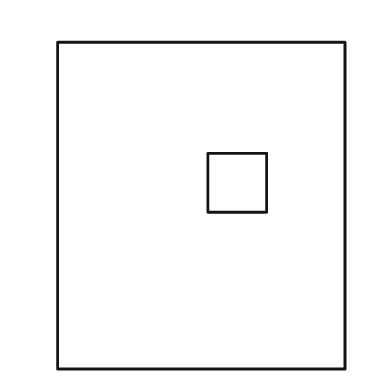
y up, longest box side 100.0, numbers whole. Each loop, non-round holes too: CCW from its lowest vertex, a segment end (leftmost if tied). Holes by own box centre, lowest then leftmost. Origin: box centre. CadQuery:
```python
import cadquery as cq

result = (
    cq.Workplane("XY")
    .moveTo(-44.0, -50.0)
    .lineTo(44.0, -50.0)
    .lineTo(44.0, 50.0)
    .lineTo(-44.0, 50.0)
    .close()
    .moveTo(2.0, -2.0)
    .lineTo(20.0, -2.0)
    .lineTo(20.0, 16.0)
    .lineTo(2.0, 16.0)
    .close()
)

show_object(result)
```